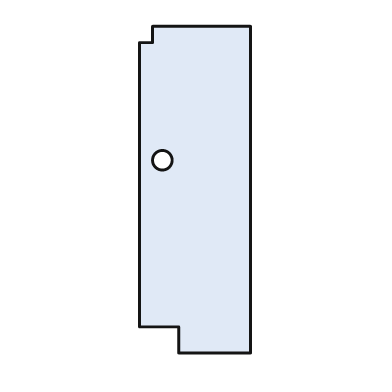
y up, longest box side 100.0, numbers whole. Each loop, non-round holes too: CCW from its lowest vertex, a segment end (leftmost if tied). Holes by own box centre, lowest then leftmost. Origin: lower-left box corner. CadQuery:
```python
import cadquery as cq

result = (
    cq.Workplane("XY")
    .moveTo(12.0, 0.0)
    .lineTo(34.0, 0.0)
    .lineTo(34.0, 100.0)
    .lineTo(4.0, 100.0)
    .lineTo(4.0, 95.0)
    .lineTo(0.0, 95.0)
    .lineTo(0.0, 8.0)
    .lineTo(12.0, 8.0)
    .close()
    .moveTo(7.0, 59.0)
    .circle(3.0)
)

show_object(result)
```